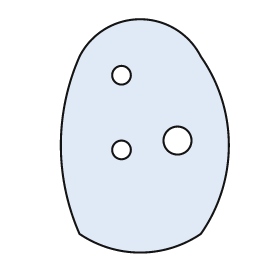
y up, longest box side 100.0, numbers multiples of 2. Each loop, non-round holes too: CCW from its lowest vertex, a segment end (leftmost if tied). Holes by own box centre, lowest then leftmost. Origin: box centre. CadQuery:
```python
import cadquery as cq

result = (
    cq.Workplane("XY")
    .moveTo(-28.0, -42.0)
    .threePointArc((-2.0, -50.0), (24.0, -42.0))
    .threePointArc((36.0, -4.0), (24.0, 34.0))
    .threePointArc((-2.0, 50.0), (-28.0, 34.0))
    .threePointArc((-36.0, -4.0), (-28.0, -42.0))
    .close()
    .moveTo(-10.0, -6.0)
    .circle(4.0)
    .moveTo(14.0, -2.0)
    .circle(6.0)
    .moveTo(-10.0, 26.0)
    .circle(4.0)
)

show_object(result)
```